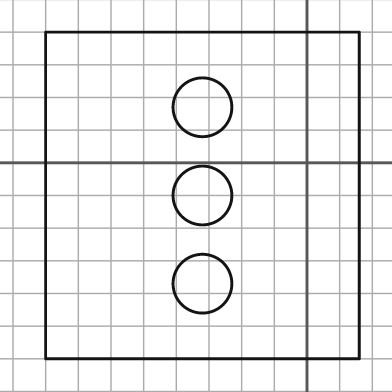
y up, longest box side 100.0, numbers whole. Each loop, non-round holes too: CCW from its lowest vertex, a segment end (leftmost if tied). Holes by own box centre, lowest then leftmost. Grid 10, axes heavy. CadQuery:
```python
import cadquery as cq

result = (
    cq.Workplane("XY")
    .moveTo(-80.0, -60.0)
    .lineTo(16.0, -60.0)
    .lineTo(16.0, 40.0)
    .lineTo(-80.0, 40.0)
    .close()
    .moveTo(-32.0, -37.0)
    .circle(9.0)
    .moveTo(-32.0, -10.0)
    .circle(9.0)
    .moveTo(-32.0, 17.0)
    .circle(9.0)
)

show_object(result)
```